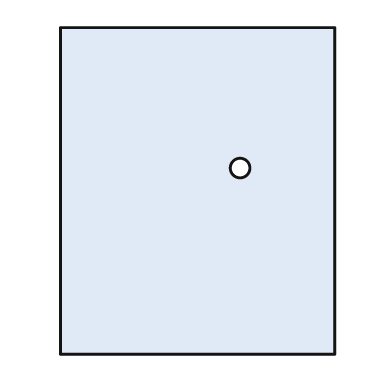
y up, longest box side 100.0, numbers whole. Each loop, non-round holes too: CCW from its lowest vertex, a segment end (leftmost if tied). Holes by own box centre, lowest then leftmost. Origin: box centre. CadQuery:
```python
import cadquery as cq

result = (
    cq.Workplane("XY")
    .moveTo(-42.0, -50.0)
    .lineTo(42.0, -50.0)
    .lineTo(42.0, 50.0)
    .lineTo(-42.0, 50.0)
    .close()
    .moveTo(13.0, 7.0)
    .circle(3.0)
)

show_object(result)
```